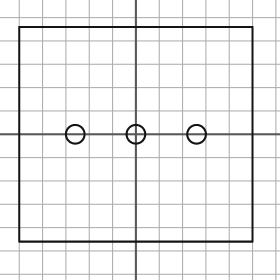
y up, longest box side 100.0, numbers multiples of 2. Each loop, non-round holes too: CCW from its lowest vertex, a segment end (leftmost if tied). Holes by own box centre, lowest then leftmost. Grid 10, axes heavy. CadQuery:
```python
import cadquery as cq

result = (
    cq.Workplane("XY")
    .moveTo(-50.0, -46.0)
    .lineTo(50.0, -46.0)
    .lineTo(50.0, 46.0)
    .lineTo(-50.0, 46.0)
    .close()
    .moveTo(-26.0, 0.0)
    .circle(4.0)
    .moveTo(0.0, 0.0)
    .circle(4.0)
    .moveTo(26.0, 0.0)
    .circle(4.0)
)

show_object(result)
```